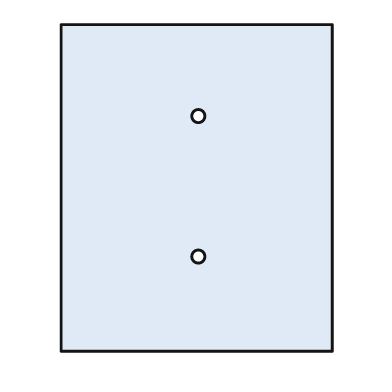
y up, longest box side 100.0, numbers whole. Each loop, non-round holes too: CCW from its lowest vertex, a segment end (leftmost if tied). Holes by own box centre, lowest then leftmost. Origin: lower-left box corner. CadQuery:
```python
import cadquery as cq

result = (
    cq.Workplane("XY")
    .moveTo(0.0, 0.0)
    .lineTo(83.0, 0.0)
    .lineTo(83.0, 100.0)
    .lineTo(0.0, 100.0)
    .close()
    .moveTo(42.0, 29.0)
    .circle(2.0)
    .moveTo(42.0, 72.0)
    .circle(2.0)
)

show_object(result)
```